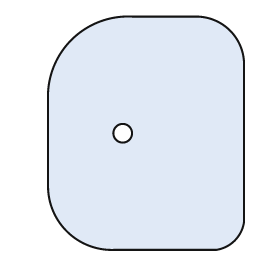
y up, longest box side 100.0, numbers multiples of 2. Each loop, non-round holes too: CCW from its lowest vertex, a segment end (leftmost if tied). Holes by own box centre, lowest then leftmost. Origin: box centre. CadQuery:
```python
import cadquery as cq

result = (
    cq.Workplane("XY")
    .moveTo(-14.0, -50.0)
    .lineTo(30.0, -50.0)
    .threePointArc((38.0, -46.0), (42.0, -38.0))
    .lineTo(42.0, 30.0)
    .threePointArc((36.0, 44.0), (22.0, 50.0))
    .lineTo(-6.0, 50.0)
    .threePointArc((-32.0, 40.0), (-42.0, 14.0))
    .lineTo(-42.0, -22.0)
    .threePointArc((-34.0, -42.0), (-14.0, -50.0))
    .close()
    .moveTo(-10.0, 0.0)
    .circle(4.0)
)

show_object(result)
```